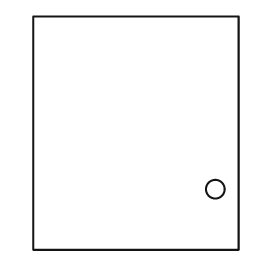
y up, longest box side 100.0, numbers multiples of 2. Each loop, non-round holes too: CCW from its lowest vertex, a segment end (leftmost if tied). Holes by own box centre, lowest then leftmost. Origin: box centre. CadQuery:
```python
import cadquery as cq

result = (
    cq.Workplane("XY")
    .moveTo(-44.0, -50.0)
    .lineTo(44.0, -50.0)
    .lineTo(44.0, 50.0)
    .lineTo(-44.0, 50.0)
    .close()
    .moveTo(34.0, -24.0)
    .circle(4.0)
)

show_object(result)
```